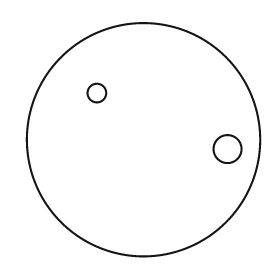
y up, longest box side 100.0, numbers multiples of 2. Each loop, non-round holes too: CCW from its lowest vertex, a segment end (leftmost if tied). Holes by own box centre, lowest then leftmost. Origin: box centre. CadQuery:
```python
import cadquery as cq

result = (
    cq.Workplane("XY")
    .moveTo(0.0, 0.0)
    .circle(50.0)
    .moveTo(36.0, -4.0)
    .circle(6.0)
    .moveTo(-20.0, 20.0)
    .circle(4.0)
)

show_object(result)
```